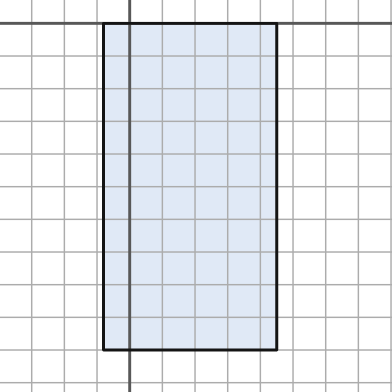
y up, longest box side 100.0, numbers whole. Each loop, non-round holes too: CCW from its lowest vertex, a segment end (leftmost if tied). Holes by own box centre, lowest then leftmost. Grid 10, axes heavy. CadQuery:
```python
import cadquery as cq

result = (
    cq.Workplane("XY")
    .moveTo(-8.0, -100.0)
    .lineTo(45.0, -100.0)
    .lineTo(45.0, 0.0)
    .lineTo(-8.0, 0.0)
    .close()
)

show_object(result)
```